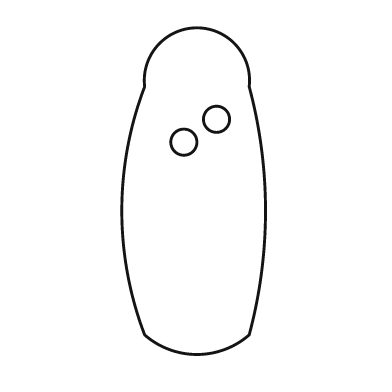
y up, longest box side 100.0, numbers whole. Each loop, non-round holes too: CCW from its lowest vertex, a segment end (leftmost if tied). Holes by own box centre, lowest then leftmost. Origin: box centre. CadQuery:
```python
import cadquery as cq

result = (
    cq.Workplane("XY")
    .moveTo(-15.0, -44.0)
    .threePointArc((1.0, -50.0), (17.0, -44.0))
    .threePointArc((22.0, -6.0), (17.0, 32.0))
    .threePointArc((1.0, 50.0), (-15.0, 32.0))
    .threePointArc((-22.0, -6.0), (-15.0, -44.0))
    .close()
    .moveTo(-3.0, 15.0)
    .circle(4.0)
    .moveTo(7.0, 22.0)
    .circle(4.0)
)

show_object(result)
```